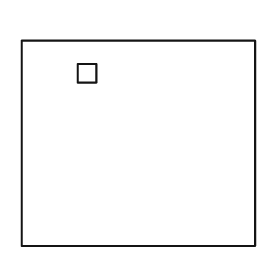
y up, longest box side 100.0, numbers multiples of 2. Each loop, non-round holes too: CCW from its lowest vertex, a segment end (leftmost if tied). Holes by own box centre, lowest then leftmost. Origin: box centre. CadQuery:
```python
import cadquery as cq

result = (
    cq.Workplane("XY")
    .moveTo(-50.0, -44.0)
    .lineTo(50.0, -44.0)
    .lineTo(50.0, 44.0)
    .lineTo(-50.0, 44.0)
    .close()
    .moveTo(-26.0, 26.0)
    .lineTo(-18.0, 26.0)
    .lineTo(-18.0, 34.0)
    .lineTo(-26.0, 34.0)
    .close()
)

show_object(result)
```